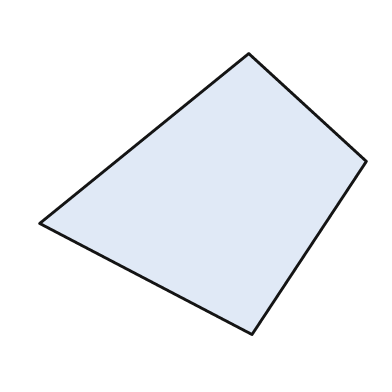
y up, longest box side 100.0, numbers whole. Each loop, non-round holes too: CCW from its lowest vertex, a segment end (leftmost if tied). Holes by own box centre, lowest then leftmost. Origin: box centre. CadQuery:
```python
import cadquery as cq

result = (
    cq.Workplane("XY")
    .moveTo(15.0, -43.0)
    .lineTo(50.0, 10.0)
    .lineTo(14.0, 43.0)
    .lineTo(-50.0, -9.0)
    .close()
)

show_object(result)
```